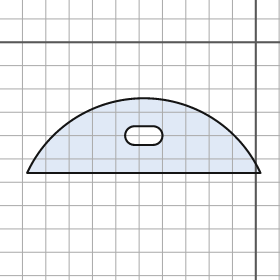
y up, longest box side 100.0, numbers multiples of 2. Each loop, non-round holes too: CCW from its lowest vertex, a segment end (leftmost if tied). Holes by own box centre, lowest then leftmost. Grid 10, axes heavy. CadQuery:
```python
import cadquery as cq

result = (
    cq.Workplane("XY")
    .moveTo(-98.0, -56.0)
    .lineTo(2.0, -56.0)
    .threePointArc((-48.0, -24.0), (-98.0, -56.0))
    .close()
    .moveTo(-52.0, -44.0)
    .lineTo(-44.0, -44.0)
    .threePointArc((-40.0, -40.0), (-44.0, -36.0))
    .lineTo(-52.0, -36.0)
    .threePointArc((-56.0, -40.0), (-52.0, -44.0))
    .close()
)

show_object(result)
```